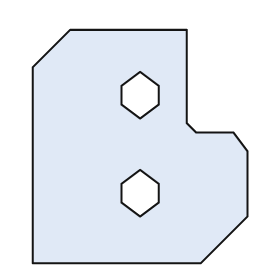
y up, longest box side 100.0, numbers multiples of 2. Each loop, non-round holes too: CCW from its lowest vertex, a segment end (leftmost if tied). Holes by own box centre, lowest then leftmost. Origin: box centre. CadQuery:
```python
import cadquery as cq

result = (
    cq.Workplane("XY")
    .moveTo(-46.0, -50.0)
    .lineTo(26.0, -50.0)
    .lineTo(46.0, -30.0)
    .lineTo(46.0, -2.0)
    .lineTo(40.0, 6.0)
    .lineTo(24.0, 6.0)
    .lineTo(20.0, 10.0)
    .lineTo(20.0, 50.0)
    .lineTo(-30.0, 50.0)
    .lineTo(-46.0, 34.0)
    .close()
    .moveTo(0.0, -30.0)
    .lineTo(8.0, -24.0)
    .lineTo(8.0, -16.0)
    .lineTo(0.0, -10.0)
    .lineTo(-8.0, -16.0)
    .lineTo(-8.0, -24.0)
    .close()
    .moveTo(0.0, 12.0)
    .lineTo(8.0, 18.0)
    .lineTo(8.0, 26.0)
    .lineTo(0.0, 32.0)
    .lineTo(-8.0, 26.0)
    .lineTo(-8.0, 18.0)
    .close()
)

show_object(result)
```